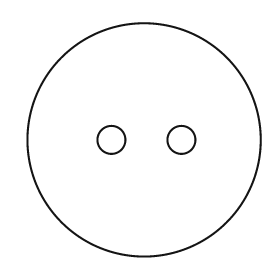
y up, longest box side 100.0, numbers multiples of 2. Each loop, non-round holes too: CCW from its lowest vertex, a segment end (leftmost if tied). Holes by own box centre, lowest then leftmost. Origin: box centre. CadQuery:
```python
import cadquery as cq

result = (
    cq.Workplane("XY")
    .moveTo(0.0, 0.0)
    .circle(50.0)
    .moveTo(-14.0, 0.0)
    .circle(6.0)
    .moveTo(16.0, 0.0)
    .circle(6.0)
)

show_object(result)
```